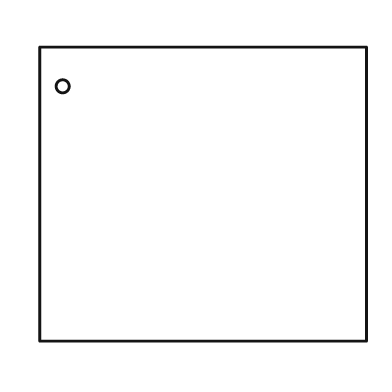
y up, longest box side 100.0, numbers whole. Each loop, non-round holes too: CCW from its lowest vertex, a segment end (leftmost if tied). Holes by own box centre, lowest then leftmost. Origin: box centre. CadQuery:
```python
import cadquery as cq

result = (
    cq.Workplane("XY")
    .moveTo(-50.0, -45.0)
    .lineTo(50.0, -45.0)
    .lineTo(50.0, 45.0)
    .lineTo(-50.0, 45.0)
    .close()
    .moveTo(-43.0, 33.0)
    .circle(2.0)
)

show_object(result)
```